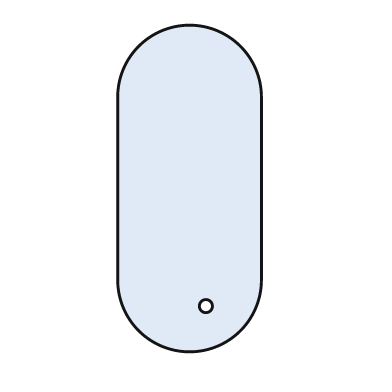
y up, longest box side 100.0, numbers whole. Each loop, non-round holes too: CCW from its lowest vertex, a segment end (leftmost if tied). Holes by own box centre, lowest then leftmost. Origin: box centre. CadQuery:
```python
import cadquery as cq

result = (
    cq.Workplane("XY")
    .moveTo(-22.0, -28.0)
    .threePointArc((0.0, -50.0), (22.0, -28.0))
    .lineTo(22.0, 28.0)
    .threePointArc((0.0, 50.0), (-22.0, 28.0))
    .close()
    .moveTo(5.0, -36.0)
    .circle(2.0)
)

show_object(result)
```